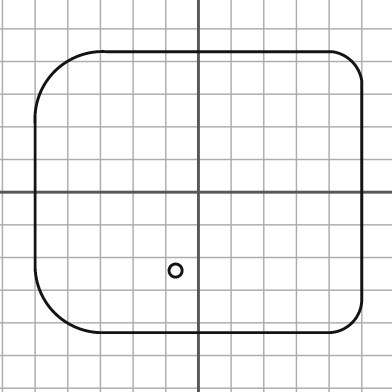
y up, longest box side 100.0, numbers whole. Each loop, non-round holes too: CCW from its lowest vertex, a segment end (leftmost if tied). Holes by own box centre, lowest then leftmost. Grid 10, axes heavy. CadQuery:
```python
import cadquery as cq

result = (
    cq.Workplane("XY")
    .moveTo(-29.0, -43.0)
    .lineTo(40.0, -43.0)
    .threePointArc((47.0, -40.0), (50.0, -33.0))
    .lineTo(50.0, 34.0)
    .threePointArc((47.0, 40.0), (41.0, 43.0))
    .lineTo(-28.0, 43.0)
    .threePointArc((-44.0, 37.0), (-50.0, 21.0))
    .lineTo(-50.0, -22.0)
    .threePointArc((-44.0, -37.0), (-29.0, -43.0))
    .close()
    .moveTo(-7.0, -24.0)
    .circle(2.0)
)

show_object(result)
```